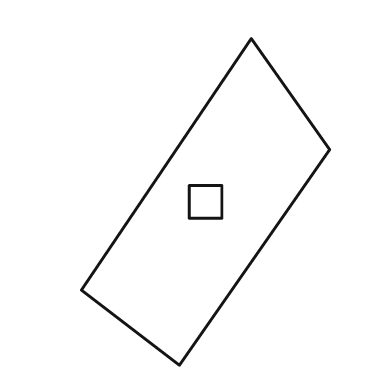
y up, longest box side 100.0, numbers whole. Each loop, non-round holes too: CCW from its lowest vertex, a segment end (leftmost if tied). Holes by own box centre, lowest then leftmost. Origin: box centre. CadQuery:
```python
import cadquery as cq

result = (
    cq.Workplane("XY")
    .moveTo(-8.0, -50.0)
    .lineTo(38.0, 16.0)
    .lineTo(14.0, 50.0)
    .lineTo(-38.0, -27.0)
    .close()
    .moveTo(-5.0, -5.0)
    .lineTo(5.0, -5.0)
    .lineTo(5.0, 5.0)
    .lineTo(-5.0, 5.0)
    .close()
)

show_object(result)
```